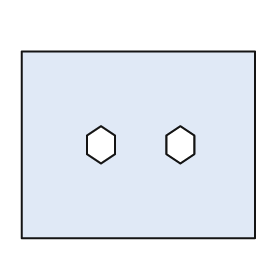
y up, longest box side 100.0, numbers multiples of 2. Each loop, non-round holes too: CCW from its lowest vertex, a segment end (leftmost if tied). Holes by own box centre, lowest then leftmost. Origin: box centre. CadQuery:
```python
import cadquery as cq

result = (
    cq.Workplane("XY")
    .moveTo(-50.0, -40.0)
    .lineTo(50.0, -40.0)
    .lineTo(50.0, 40.0)
    .lineTo(-50.0, 40.0)
    .close()
    .moveTo(-16.0, -8.0)
    .lineTo(-10.0, -4.0)
    .lineTo(-10.0, 4.0)
    .lineTo(-16.0, 8.0)
    .lineTo(-22.0, 4.0)
    .lineTo(-22.0, -4.0)
    .close()
    .moveTo(18.0, -8.0)
    .lineTo(24.0, -4.0)
    .lineTo(24.0, 4.0)
    .lineTo(18.0, 8.0)
    .lineTo(12.0, 4.0)
    .lineTo(12.0, -4.0)
    .close()
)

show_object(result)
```